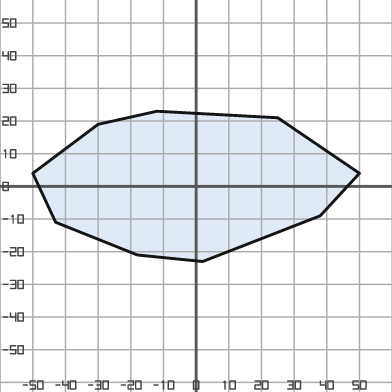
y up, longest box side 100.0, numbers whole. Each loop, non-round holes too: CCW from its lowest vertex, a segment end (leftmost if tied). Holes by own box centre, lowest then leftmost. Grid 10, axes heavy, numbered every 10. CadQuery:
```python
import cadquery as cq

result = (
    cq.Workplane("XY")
    .moveTo(2.0, -23.0)
    .lineTo(38.0, -9.0)
    .lineTo(50.0, 4.0)
    .lineTo(25.0, 21.0)
    .lineTo(-12.0, 23.0)
    .lineTo(-30.0, 19.0)
    .lineTo(-50.0, 4.0)
    .lineTo(-43.0, -11.0)
    .lineTo(-18.0, -21.0)
    .close()
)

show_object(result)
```